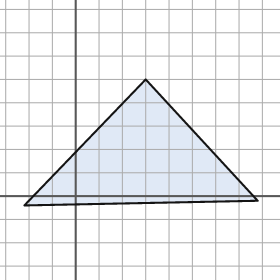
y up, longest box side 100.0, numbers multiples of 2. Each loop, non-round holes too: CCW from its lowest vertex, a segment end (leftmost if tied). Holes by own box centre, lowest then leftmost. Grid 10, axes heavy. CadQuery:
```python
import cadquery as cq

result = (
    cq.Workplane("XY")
    .moveTo(-22.0, -4.0)
    .lineTo(78.0, -2.0)
    .lineTo(30.0, 50.0)
    .close()
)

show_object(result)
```